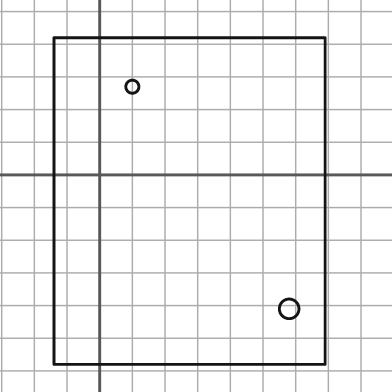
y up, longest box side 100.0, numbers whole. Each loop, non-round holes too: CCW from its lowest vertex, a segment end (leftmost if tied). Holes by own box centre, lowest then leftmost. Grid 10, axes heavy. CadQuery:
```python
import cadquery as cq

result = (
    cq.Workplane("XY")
    .moveTo(-14.0, -58.0)
    .lineTo(69.0, -58.0)
    .lineTo(69.0, 42.0)
    .lineTo(-14.0, 42.0)
    .close()
    .moveTo(58.0, -41.0)
    .circle(3.0)
    .moveTo(10.0, 27.0)
    .circle(2.0)
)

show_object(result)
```